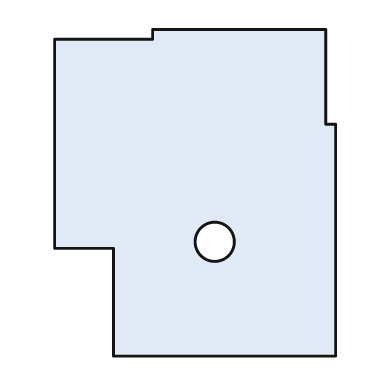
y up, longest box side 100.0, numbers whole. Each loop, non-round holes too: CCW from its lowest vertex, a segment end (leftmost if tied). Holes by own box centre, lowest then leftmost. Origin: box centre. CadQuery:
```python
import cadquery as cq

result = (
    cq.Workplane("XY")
    .moveTo(-25.0, -50.0)
    .lineTo(43.0, -50.0)
    .lineTo(43.0, 21.0)
    .lineTo(40.0, 21.0)
    .lineTo(40.0, 50.0)
    .lineTo(-13.0, 50.0)
    .lineTo(-13.0, 47.0)
    .lineTo(-43.0, 47.0)
    .lineTo(-43.0, -17.0)
    .lineTo(-25.0, -17.0)
    .close()
    .moveTo(6.0, -15.0)
    .circle(6.0)
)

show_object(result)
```